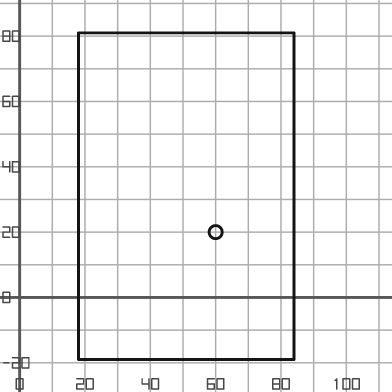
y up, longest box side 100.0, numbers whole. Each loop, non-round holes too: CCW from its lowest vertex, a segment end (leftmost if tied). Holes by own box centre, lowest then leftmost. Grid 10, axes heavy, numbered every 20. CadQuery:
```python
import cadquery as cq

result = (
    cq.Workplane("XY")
    .moveTo(18.0, -19.0)
    .lineTo(84.0, -19.0)
    .lineTo(84.0, 81.0)
    .lineTo(18.0, 81.0)
    .close()
    .moveTo(60.0, 20.0)
    .circle(2.0)
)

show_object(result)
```